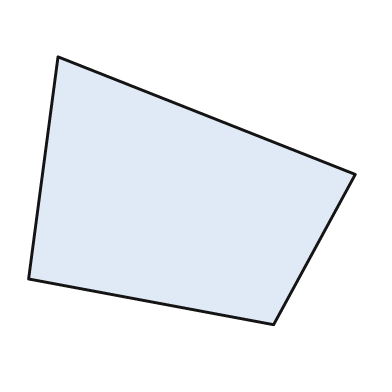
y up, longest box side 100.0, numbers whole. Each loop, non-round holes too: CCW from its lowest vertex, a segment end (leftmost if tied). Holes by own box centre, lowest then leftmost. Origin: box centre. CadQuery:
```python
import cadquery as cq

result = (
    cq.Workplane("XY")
    .moveTo(25.0, -41.0)
    .lineTo(50.0, 5.0)
    .lineTo(-41.0, 41.0)
    .lineTo(-50.0, -27.0)
    .close()
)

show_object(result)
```